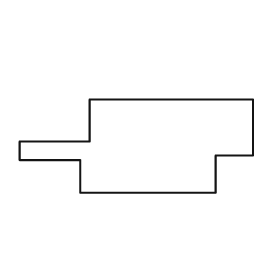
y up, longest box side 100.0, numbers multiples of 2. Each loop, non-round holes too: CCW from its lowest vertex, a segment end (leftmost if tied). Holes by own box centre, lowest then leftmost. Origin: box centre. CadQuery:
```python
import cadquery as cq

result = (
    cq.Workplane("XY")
    .moveTo(-24.0, -20.0)
    .lineTo(34.0, -20.0)
    .lineTo(34.0, -4.0)
    .lineTo(50.0, -4.0)
    .lineTo(50.0, 20.0)
    .lineTo(-20.0, 20.0)
    .lineTo(-20.0, 2.0)
    .lineTo(-50.0, 2.0)
    .lineTo(-50.0, -6.0)
    .lineTo(-24.0, -6.0)
    .close()
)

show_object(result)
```